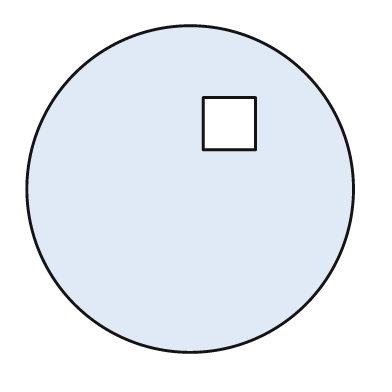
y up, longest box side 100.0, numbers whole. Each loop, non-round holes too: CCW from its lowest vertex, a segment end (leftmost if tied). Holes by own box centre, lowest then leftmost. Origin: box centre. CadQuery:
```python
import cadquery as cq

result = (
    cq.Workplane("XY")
    .moveTo(0.0, 0.0)
    .circle(50.0)
    .moveTo(4.0, 12.0)
    .lineTo(20.0, 12.0)
    .lineTo(20.0, 28.0)
    .lineTo(4.0, 28.0)
    .close()
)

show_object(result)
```